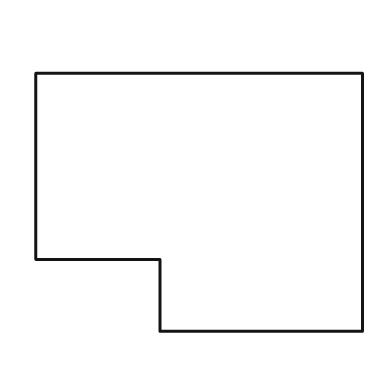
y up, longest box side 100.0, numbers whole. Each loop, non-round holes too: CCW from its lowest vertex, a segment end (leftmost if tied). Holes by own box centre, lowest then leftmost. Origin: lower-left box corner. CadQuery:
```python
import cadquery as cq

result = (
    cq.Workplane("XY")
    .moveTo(38.0, 0.0)
    .lineTo(100.0, 0.0)
    .lineTo(100.0, 79.0)
    .lineTo(0.0, 79.0)
    .lineTo(0.0, 22.0)
    .lineTo(38.0, 22.0)
    .close()
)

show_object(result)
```